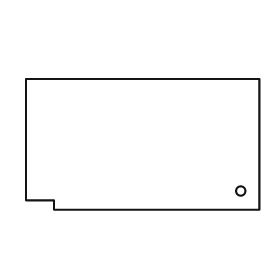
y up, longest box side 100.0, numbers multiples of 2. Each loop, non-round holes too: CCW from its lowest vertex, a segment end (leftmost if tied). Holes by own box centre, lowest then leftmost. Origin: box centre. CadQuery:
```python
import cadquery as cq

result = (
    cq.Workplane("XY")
    .moveTo(-38.0, -28.0)
    .lineTo(50.0, -28.0)
    .lineTo(50.0, 28.0)
    .lineTo(-50.0, 28.0)
    .lineTo(-50.0, -24.0)
    .lineTo(-38.0, -24.0)
    .close()
    .moveTo(42.0, -20.0)
    .circle(2.0)
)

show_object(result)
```